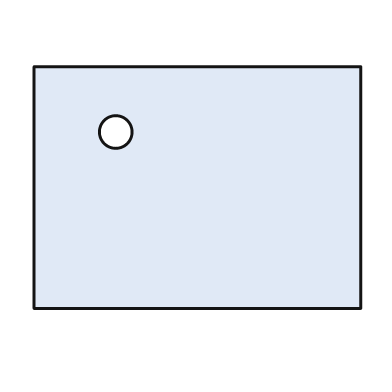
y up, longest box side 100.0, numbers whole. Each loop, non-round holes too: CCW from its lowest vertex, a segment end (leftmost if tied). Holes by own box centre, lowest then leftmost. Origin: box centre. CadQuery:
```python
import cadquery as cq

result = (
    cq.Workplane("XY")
    .moveTo(-50.0, -37.0)
    .lineTo(50.0, -37.0)
    .lineTo(50.0, 37.0)
    .lineTo(-50.0, 37.0)
    .close()
    .moveTo(-25.0, 17.0)
    .circle(5.0)
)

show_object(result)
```